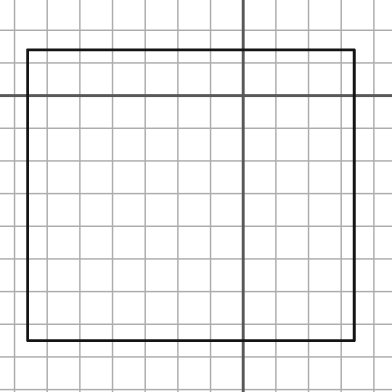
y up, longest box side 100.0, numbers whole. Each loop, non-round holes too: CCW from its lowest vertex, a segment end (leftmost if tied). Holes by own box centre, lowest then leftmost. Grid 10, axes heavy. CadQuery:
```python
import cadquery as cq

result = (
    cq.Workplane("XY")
    .moveTo(-66.0, -75.0)
    .lineTo(34.0, -75.0)
    .lineTo(34.0, 14.0)
    .lineTo(-66.0, 14.0)
    .close()
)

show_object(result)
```